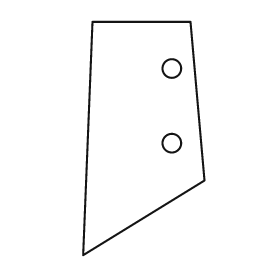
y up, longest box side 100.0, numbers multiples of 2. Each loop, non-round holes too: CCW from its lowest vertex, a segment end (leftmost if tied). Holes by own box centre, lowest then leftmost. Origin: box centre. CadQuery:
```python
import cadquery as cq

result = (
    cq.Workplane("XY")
    .moveTo(-26.0, -50.0)
    .lineTo(26.0, -18.0)
    .lineTo(20.0, 50.0)
    .lineTo(-22.0, 50.0)
    .close()
    .moveTo(12.0, -2.0)
    .circle(4.0)
    .moveTo(12.0, 30.0)
    .circle(4.0)
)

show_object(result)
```